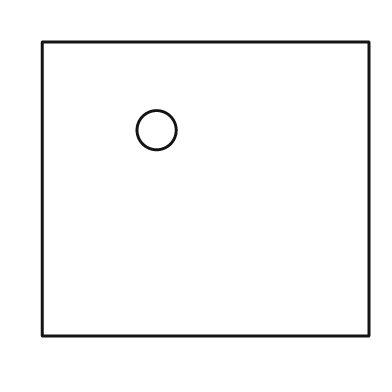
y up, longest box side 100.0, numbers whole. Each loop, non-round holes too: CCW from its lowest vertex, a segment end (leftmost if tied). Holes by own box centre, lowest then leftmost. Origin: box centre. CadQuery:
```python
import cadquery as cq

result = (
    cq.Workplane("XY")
    .moveTo(-50.0, -45.0)
    .lineTo(50.0, -45.0)
    .lineTo(50.0, 45.0)
    .lineTo(-50.0, 45.0)
    .close()
    .moveTo(-15.0, 18.0)
    .circle(6.0)
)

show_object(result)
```